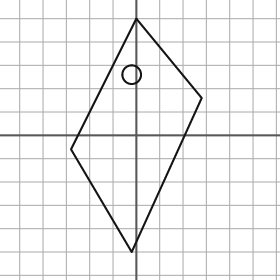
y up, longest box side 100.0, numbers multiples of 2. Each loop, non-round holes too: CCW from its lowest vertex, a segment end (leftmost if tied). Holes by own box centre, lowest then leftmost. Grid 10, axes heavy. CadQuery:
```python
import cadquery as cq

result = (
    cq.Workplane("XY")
    .moveTo(-2.0, -50.0)
    .lineTo(28.0, 16.0)
    .lineTo(0.0, 50.0)
    .lineTo(-28.0, -6.0)
    .close()
    .moveTo(-2.0, 26.0)
    .circle(4.0)
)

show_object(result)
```